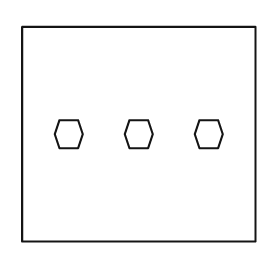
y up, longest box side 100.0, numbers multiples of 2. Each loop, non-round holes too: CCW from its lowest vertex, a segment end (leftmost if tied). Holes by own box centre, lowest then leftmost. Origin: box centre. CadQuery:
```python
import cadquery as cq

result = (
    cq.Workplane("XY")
    .moveTo(-50.0, -46.0)
    .lineTo(50.0, -46.0)
    .lineTo(50.0, 46.0)
    .lineTo(-50.0, 46.0)
    .close()
    .moveTo(-34.0, -6.0)
    .lineTo(-26.0, -6.0)
    .lineTo(-24.0, 0.0)
    .lineTo(-26.0, 6.0)
    .lineTo(-34.0, 6.0)
    .lineTo(-36.0, 0.0)
    .close()
    .moveTo(-4.0, -6.0)
    .lineTo(4.0, -6.0)
    .lineTo(6.0, 0.0)
    .lineTo(4.0, 6.0)
    .lineTo(-4.0, 6.0)
    .lineTo(-6.0, 0.0)
    .close()
    .moveTo(26.0, -6.0)
    .lineTo(34.0, -6.0)
    .lineTo(36.0, 0.0)
    .lineTo(34.0, 6.0)
    .lineTo(26.0, 6.0)
    .lineTo(24.0, 0.0)
    .close()
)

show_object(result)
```